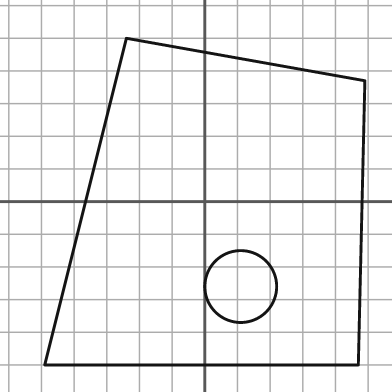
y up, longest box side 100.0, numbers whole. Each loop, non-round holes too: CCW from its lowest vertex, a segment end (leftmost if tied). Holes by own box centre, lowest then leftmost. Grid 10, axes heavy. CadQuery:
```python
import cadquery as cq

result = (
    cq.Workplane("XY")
    .moveTo(-49.0, -50.0)
    .lineTo(47.0, -50.0)
    .lineTo(49.0, 37.0)
    .lineTo(-24.0, 50.0)
    .close()
    .moveTo(11.0, -26.0)
    .circle(11.0)
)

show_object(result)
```